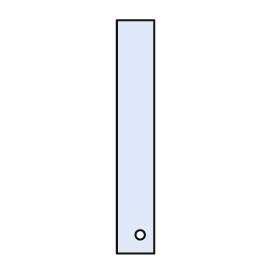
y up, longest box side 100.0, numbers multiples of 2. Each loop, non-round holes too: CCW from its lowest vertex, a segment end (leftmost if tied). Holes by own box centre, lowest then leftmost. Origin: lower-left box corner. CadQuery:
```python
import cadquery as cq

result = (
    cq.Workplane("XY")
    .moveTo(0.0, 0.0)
    .lineTo(16.0, 0.0)
    .lineTo(16.0, 100.0)
    .lineTo(0.0, 100.0)
    .close()
    .moveTo(10.0, 8.0)
    .circle(2.0)
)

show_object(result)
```